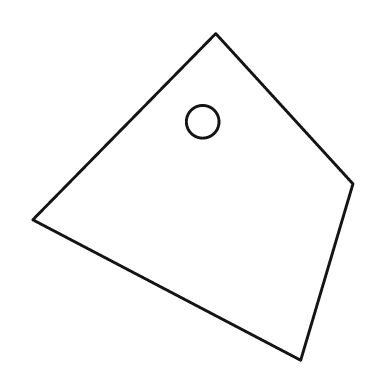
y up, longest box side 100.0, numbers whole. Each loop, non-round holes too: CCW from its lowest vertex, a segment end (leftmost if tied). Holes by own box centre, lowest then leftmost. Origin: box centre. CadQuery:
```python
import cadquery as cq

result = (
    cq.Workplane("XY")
    .moveTo(33.0, -50.0)
    .lineTo(49.0, 4.0)
    .lineTo(7.0, 50.0)
    .lineTo(-49.0, -7.0)
    .close()
    .moveTo(3.0, 23.0)
    .circle(5.0)
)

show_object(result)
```